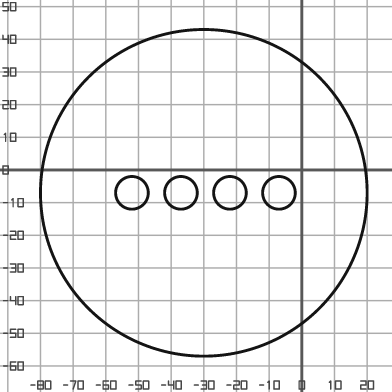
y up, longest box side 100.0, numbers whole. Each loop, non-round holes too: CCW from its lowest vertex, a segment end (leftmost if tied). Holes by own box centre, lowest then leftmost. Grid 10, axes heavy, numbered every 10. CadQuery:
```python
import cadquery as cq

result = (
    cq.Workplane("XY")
    .moveTo(-30.0, -7.0)
    .circle(50.0)
    .moveTo(-52.0, -7.0)
    .circle(5.0)
    .moveTo(-37.0, -7.0)
    .circle(5.0)
    .moveTo(-22.0, -7.0)
    .circle(5.0)
    .moveTo(-7.0, -7.0)
    .circle(5.0)
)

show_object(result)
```